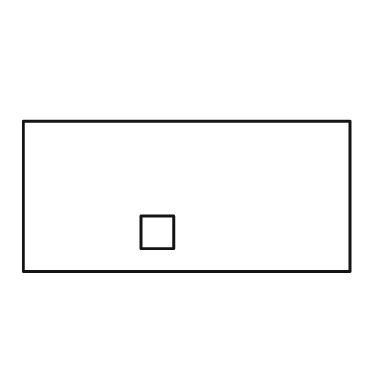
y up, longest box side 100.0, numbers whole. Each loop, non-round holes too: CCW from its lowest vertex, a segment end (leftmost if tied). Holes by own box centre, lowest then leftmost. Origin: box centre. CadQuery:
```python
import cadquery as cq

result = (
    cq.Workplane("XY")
    .moveTo(-50.0, -23.0)
    .lineTo(50.0, -23.0)
    .lineTo(50.0, 23.0)
    .lineTo(-50.0, 23.0)
    .close()
    .moveTo(-14.0, -16.0)
    .lineTo(-4.0, -16.0)
    .lineTo(-4.0, -6.0)
    .lineTo(-14.0, -6.0)
    .close()
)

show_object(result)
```